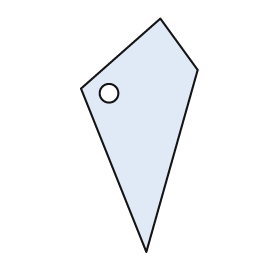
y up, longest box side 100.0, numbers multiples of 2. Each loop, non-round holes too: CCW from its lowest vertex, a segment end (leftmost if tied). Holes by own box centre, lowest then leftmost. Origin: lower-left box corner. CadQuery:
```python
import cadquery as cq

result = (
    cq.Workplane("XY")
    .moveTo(28.0, 0.0)
    .lineTo(50.0, 78.0)
    .lineTo(34.0, 100.0)
    .lineTo(0.0, 70.0)
    .close()
    .moveTo(12.0, 68.0)
    .circle(4.0)
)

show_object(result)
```